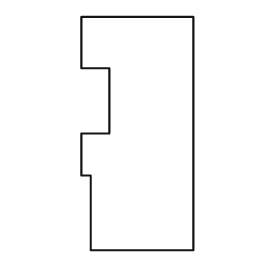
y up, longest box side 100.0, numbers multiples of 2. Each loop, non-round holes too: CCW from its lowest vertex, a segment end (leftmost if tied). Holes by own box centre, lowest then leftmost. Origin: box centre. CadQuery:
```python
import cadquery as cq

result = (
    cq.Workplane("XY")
    .moveTo(-20.0, -50.0)
    .lineTo(24.0, -50.0)
    .lineTo(24.0, 50.0)
    .lineTo(-24.0, 50.0)
    .lineTo(-24.0, 28.0)
    .lineTo(-12.0, 28.0)
    .lineTo(-12.0, 0.0)
    .lineTo(-24.0, 0.0)
    .lineTo(-24.0, -18.0)
    .lineTo(-20.0, -18.0)
    .close()
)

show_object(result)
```